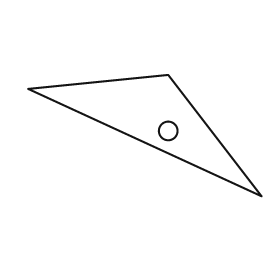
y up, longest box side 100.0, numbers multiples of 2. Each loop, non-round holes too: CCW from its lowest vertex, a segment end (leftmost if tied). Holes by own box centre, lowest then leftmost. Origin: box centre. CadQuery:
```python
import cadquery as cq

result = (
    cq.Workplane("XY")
    .moveTo(50.0, -26.0)
    .lineTo(10.0, 26.0)
    .lineTo(-50.0, 20.0)
    .close()
    .moveTo(10.0, 2.0)
    .circle(4.0)
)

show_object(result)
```